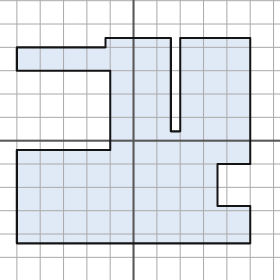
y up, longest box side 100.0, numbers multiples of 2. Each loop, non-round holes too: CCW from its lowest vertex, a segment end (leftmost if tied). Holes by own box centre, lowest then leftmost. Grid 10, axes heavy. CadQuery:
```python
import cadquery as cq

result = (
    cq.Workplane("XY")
    .moveTo(-50.0, -44.0)
    .lineTo(50.0, -44.0)
    .lineTo(50.0, -28.0)
    .lineTo(36.0, -28.0)
    .lineTo(36.0, -10.0)
    .lineTo(50.0, -10.0)
    .lineTo(50.0, 44.0)
    .lineTo(20.0, 44.0)
    .lineTo(20.0, 4.0)
    .lineTo(16.0, 4.0)
    .lineTo(16.0, 44.0)
    .lineTo(-12.0, 44.0)
    .lineTo(-12.0, 40.0)
    .lineTo(-50.0, 40.0)
    .lineTo(-50.0, 30.0)
    .lineTo(-10.0, 30.0)
    .lineTo(-10.0, -4.0)
    .lineTo(-50.0, -4.0)
    .close()
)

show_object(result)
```